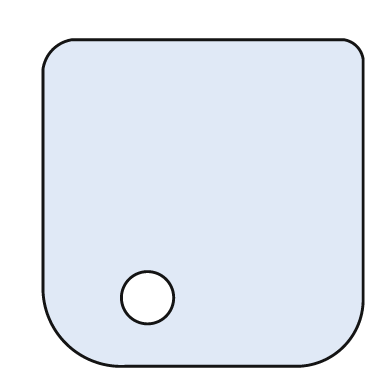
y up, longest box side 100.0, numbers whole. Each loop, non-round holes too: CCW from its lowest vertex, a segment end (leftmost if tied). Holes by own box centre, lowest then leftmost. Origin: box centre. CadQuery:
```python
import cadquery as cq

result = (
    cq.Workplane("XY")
    .moveTo(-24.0, -50.0)
    .lineTo(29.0, -50.0)
    .threePointArc((43.0, -44.0), (49.0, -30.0))
    .lineTo(49.0, 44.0)
    .threePointArc((47.0, 48.0), (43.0, 50.0))
    .lineTo(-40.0, 50.0)
    .threePointArc((-46.0, 47.0), (-49.0, 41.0))
    .lineTo(-49.0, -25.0)
    .threePointArc((-42.0, -43.0), (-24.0, -50.0))
    .close()
    .moveTo(-17.0, -29.0)
    .circle(8.0)
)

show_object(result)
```